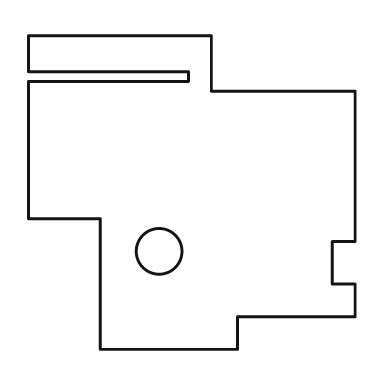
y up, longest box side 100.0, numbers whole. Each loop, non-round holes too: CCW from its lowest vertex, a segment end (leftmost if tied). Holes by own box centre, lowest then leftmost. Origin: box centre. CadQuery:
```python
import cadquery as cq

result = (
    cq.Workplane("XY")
    .moveTo(-28.0, -48.0)
    .lineTo(14.0, -48.0)
    .lineTo(14.0, -38.0)
    .lineTo(50.0, -38.0)
    .lineTo(50.0, -28.0)
    .lineTo(43.0, -28.0)
    .lineTo(43.0, -15.0)
    .lineTo(50.0, -15.0)
    .lineTo(50.0, 31.0)
    .lineTo(6.0, 31.0)
    .lineTo(6.0, 48.0)
    .lineTo(-50.0, 48.0)
    .lineTo(-50.0, 37.0)
    .lineTo(-1.0, 37.0)
    .lineTo(-1.0, 34.0)
    .lineTo(-50.0, 34.0)
    .lineTo(-50.0, -8.0)
    .lineTo(-28.0, -8.0)
    .close()
    .moveTo(-10.0, -18.0)
    .circle(7.0)
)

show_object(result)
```